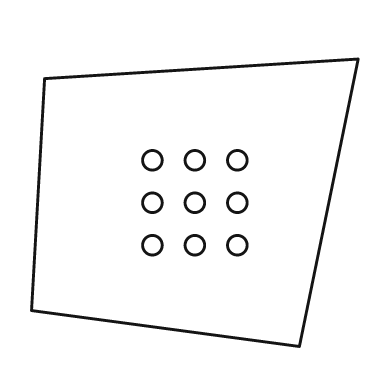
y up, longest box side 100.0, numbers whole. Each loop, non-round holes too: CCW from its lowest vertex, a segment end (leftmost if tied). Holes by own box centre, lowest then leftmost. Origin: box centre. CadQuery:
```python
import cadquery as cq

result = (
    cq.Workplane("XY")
    .moveTo(32.0, -44.0)
    .lineTo(50.0, 44.0)
    .lineTo(-46.0, 38.0)
    .lineTo(-50.0, -33.0)
    .close()
    .moveTo(-13.0, -13.0)
    .circle(3.0)
    .moveTo(0.0, -13.0)
    .circle(3.0)
    .moveTo(13.0, -13.0)
    .circle(3.0)
    .moveTo(-13.0, 0.0)
    .circle(3.0)
    .moveTo(0.0, 0.0)
    .circle(3.0)
    .moveTo(13.0, 0.0)
    .circle(3.0)
    .moveTo(-13.0, 13.0)
    .circle(3.0)
    .moveTo(0.0, 13.0)
    .circle(3.0)
    .moveTo(13.0, 13.0)
    .circle(3.0)
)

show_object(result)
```